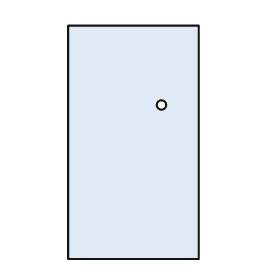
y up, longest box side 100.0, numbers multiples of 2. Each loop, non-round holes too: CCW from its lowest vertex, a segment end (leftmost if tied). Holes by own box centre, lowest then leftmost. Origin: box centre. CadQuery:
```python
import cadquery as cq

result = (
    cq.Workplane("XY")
    .moveTo(-28.0, -50.0)
    .lineTo(28.0, -50.0)
    .lineTo(28.0, 50.0)
    .lineTo(-28.0, 50.0)
    .close()
    .moveTo(12.0, 16.0)
    .circle(2.0)
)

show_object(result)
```